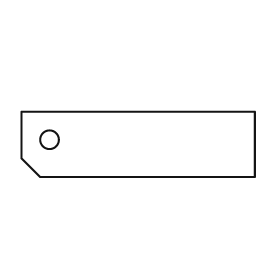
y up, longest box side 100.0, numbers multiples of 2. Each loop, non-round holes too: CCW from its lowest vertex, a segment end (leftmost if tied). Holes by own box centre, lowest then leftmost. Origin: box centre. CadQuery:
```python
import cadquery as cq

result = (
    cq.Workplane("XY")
    .moveTo(-42.0, -14.0)
    .lineTo(50.0, -14.0)
    .lineTo(50.0, 14.0)
    .lineTo(-50.0, 14.0)
    .lineTo(-50.0, -6.0)
    .close()
    .moveTo(-38.0, 2.0)
    .circle(4.0)
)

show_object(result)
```